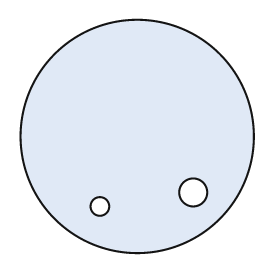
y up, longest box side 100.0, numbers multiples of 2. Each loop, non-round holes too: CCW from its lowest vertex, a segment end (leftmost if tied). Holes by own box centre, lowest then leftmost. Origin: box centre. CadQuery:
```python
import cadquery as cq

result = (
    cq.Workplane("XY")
    .moveTo(0.0, 0.0)
    .circle(50.0)
    .moveTo(-16.0, -30.0)
    .circle(4.0)
    .moveTo(24.0, -24.0)
    .circle(6.0)
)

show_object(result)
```